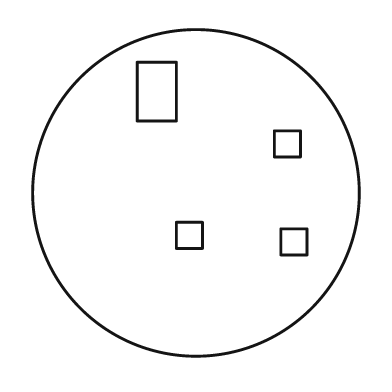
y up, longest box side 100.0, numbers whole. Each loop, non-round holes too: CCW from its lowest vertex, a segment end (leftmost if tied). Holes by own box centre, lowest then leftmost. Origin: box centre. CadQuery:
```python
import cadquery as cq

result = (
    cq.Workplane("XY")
    .moveTo(0.0, 0.0)
    .circle(50.0)
    .moveTo(26.0, -19.0)
    .lineTo(34.0, -19.0)
    .lineTo(34.0, -11.0)
    .lineTo(26.0, -11.0)
    .close()
    .moveTo(-6.0, -17.0)
    .lineTo(2.0, -17.0)
    .lineTo(2.0, -9.0)
    .lineTo(-6.0, -9.0)
    .close()
    .moveTo(24.0, 11.0)
    .lineTo(32.0, 11.0)
    .lineTo(32.0, 19.0)
    .lineTo(24.0, 19.0)
    .close()
    .moveTo(-18.0, 22.0)
    .lineTo(-6.0, 22.0)
    .lineTo(-6.0, 40.0)
    .lineTo(-18.0, 40.0)
    .close()
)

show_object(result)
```